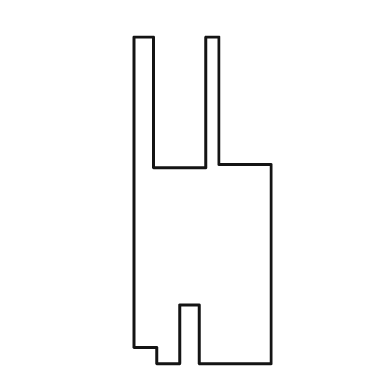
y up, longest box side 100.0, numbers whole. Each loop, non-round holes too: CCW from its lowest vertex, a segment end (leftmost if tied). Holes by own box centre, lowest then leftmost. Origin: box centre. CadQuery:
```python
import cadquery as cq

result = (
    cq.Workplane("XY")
    .moveTo(-14.0, -50.0)
    .lineTo(-7.0, -50.0)
    .lineTo(-7.0, -32.0)
    .lineTo(-1.0, -32.0)
    .lineTo(-1.0, -50.0)
    .lineTo(21.0, -50.0)
    .lineTo(21.0, 11.0)
    .lineTo(5.0, 11.0)
    .lineTo(5.0, 50.0)
    .lineTo(1.0, 50.0)
    .lineTo(1.0, 10.0)
    .lineTo(-15.0, 10.0)
    .lineTo(-15.0, 50.0)
    .lineTo(-21.0, 50.0)
    .lineTo(-21.0, -45.0)
    .lineTo(-14.0, -45.0)
    .close()
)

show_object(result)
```